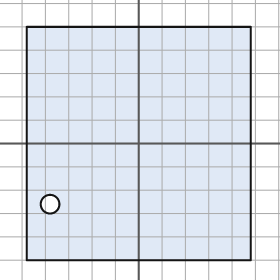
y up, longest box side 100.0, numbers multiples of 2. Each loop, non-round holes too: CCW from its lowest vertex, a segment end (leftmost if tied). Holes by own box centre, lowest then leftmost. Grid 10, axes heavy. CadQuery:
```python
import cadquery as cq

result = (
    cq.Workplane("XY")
    .moveTo(-48.0, -50.0)
    .lineTo(48.0, -50.0)
    .lineTo(48.0, 50.0)
    .lineTo(-48.0, 50.0)
    .close()
    .moveTo(-38.0, -26.0)
    .circle(4.0)
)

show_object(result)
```